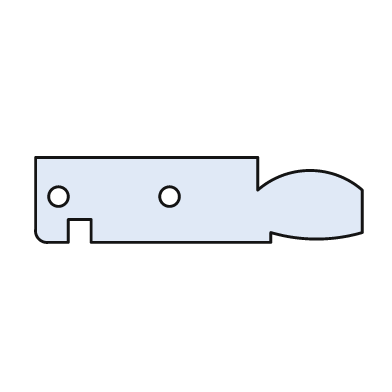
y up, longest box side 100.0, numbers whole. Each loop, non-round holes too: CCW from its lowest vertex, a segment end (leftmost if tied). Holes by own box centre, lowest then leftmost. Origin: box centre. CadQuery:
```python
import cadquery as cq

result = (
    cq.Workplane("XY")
    .moveTo(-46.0, -13.0)
    .lineTo(-40.0, -13.0)
    .lineTo(-40.0, -6.0)
    .lineTo(-33.0, -6.0)
    .lineTo(-33.0, -13.0)
    .lineTo(22.0, -13.0)
    .lineTo(22.0, -10.0)
    .threePointArc((36.0, -12.0), (50.0, -10.0))
    .lineTo(50.0, 3.0)
    .threePointArc((34.0, 9.0), (18.0, 3.0))
    .lineTo(18.0, 13.0)
    .lineTo(-50.0, 13.0)
    .lineTo(-50.0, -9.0)
    .threePointArc((-49.0, -12.0), (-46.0, -13.0))
    .close()
    .moveTo(-43.0, 1.0)
    .circle(3.0)
    .moveTo(-9.0, 1.0)
    .circle(3.0)
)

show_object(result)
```